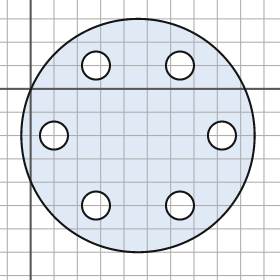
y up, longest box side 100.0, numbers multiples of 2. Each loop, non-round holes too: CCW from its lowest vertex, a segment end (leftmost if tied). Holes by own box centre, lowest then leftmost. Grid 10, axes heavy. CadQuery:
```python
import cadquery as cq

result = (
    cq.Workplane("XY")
    .moveTo(46.0, -20.0)
    .circle(50.0)
    .moveTo(28.0, -50.0)
    .circle(6.0)
    .moveTo(64.0, -50.0)
    .circle(6.0)
    .moveTo(10.0, -20.0)
    .circle(6.0)
    .moveTo(82.0, -20.0)
    .circle(6.0)
    .moveTo(28.0, 10.0)
    .circle(6.0)
    .moveTo(64.0, 10.0)
    .circle(6.0)
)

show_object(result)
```